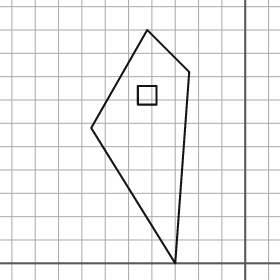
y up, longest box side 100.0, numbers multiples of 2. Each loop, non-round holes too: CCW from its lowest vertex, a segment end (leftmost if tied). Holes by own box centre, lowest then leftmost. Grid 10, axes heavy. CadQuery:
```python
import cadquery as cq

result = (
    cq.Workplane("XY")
    .moveTo(-30.0, 0.0)
    .lineTo(-24.0, 82.0)
    .lineTo(-42.0, 100.0)
    .lineTo(-66.0, 58.0)
    .close()
    .moveTo(-46.0, 68.0)
    .lineTo(-38.0, 68.0)
    .lineTo(-38.0, 76.0)
    .lineTo(-46.0, 76.0)
    .close()
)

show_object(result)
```